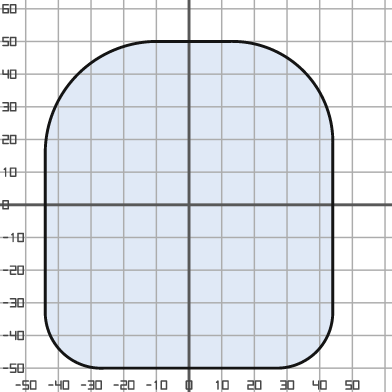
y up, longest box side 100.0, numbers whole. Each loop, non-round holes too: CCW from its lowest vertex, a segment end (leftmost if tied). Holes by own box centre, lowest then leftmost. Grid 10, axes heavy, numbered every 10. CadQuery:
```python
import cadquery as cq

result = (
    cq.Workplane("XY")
    .moveTo(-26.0, -50.0)
    .lineTo(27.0, -50.0)
    .threePointArc((39.0, -45.0), (44.0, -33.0))
    .lineTo(44.0, 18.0)
    .threePointArc((35.0, 41.0), (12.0, 50.0))
    .lineTo(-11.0, 50.0)
    .threePointArc((-34.0, 40.0), (-44.0, 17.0))
    .lineTo(-44.0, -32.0)
    .threePointArc((-39.0, -45.0), (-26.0, -50.0))
    .close()
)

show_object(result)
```